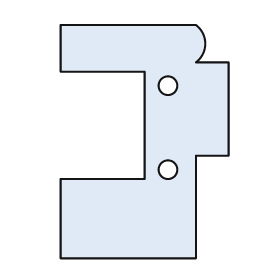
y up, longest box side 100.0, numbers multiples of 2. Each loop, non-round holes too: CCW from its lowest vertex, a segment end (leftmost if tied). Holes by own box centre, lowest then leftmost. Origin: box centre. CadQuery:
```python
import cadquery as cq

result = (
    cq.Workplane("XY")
    .moveTo(-36.0, -50.0)
    .lineTo(22.0, -50.0)
    .lineTo(22.0, -6.0)
    .lineTo(36.0, -6.0)
    .lineTo(36.0, 34.0)
    .lineTo(22.0, 34.0)
    .threePointArc((26.0, 42.0), (22.0, 50.0))
    .lineTo(-36.0, 50.0)
    .lineTo(-36.0, 30.0)
    .lineTo(0.0, 30.0)
    .lineTo(0.0, -16.0)
    .lineTo(-36.0, -16.0)
    .close()
    .moveTo(10.0, -12.0)
    .circle(4.0)
    .moveTo(10.0, 24.0)
    .circle(4.0)
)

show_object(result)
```